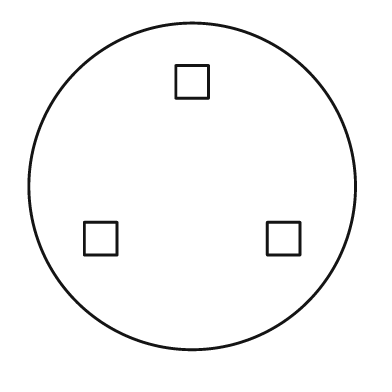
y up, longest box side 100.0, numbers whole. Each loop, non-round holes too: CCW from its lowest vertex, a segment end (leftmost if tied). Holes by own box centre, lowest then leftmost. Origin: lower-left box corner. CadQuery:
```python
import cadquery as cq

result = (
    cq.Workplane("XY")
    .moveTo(50.0, 50.0)
    .circle(50.0)
    .moveTo(17.0, 29.0)
    .lineTo(27.0, 29.0)
    .lineTo(27.0, 39.0)
    .lineTo(17.0, 39.0)
    .close()
    .moveTo(73.0, 29.0)
    .lineTo(83.0, 29.0)
    .lineTo(83.0, 39.0)
    .lineTo(73.0, 39.0)
    .close()
    .moveTo(45.0, 77.0)
    .lineTo(55.0, 77.0)
    .lineTo(55.0, 87.0)
    .lineTo(45.0, 87.0)
    .close()
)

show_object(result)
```